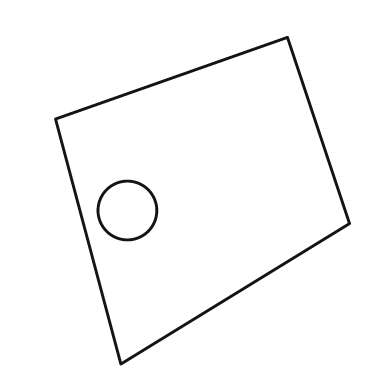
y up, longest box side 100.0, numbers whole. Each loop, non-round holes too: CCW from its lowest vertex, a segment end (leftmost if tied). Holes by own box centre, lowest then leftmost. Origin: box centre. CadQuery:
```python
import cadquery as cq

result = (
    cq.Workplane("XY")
    .moveTo(-25.0, -50.0)
    .lineTo(45.0, -7.0)
    .lineTo(26.0, 50.0)
    .lineTo(-45.0, 25.0)
    .close()
    .moveTo(-23.0, -3.0)
    .circle(9.0)
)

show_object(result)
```